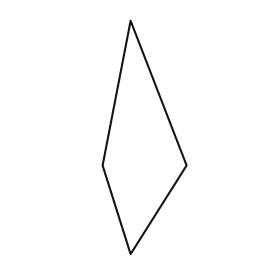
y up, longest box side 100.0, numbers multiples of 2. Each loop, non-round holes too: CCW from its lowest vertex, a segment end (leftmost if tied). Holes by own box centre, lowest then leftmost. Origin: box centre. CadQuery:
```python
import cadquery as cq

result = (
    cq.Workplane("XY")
    .moveTo(-6.0, -50.0)
    .lineTo(18.0, -12.0)
    .lineTo(-6.0, 50.0)
    .lineTo(-18.0, -12.0)
    .close()
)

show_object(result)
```